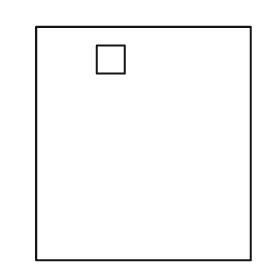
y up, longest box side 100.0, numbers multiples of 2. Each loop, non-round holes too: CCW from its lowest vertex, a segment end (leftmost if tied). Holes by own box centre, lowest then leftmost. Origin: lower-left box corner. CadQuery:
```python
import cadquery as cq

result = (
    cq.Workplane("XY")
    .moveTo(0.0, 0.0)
    .lineTo(92.0, 0.0)
    .lineTo(92.0, 100.0)
    .lineTo(0.0, 100.0)
    .close()
    .moveTo(26.0, 80.0)
    .lineTo(38.0, 80.0)
    .lineTo(38.0, 92.0)
    .lineTo(26.0, 92.0)
    .close()
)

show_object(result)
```